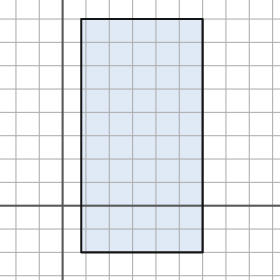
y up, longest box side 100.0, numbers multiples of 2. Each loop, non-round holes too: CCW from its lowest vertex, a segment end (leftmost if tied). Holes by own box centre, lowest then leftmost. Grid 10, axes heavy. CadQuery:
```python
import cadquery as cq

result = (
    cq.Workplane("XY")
    .moveTo(8.0, -20.0)
    .lineTo(60.0, -20.0)
    .lineTo(60.0, 80.0)
    .lineTo(8.0, 80.0)
    .close()
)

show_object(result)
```